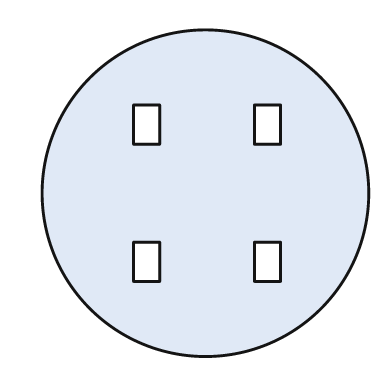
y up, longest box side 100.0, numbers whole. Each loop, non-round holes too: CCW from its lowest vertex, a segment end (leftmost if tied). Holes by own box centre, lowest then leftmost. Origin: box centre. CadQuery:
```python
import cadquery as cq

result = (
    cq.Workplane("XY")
    .moveTo(0.0, 0.0)
    .circle(50.0)
    .moveTo(-22.0, -27.0)
    .lineTo(-14.0, -27.0)
    .lineTo(-14.0, -15.0)
    .lineTo(-22.0, -15.0)
    .close()
    .moveTo(15.0, -27.0)
    .lineTo(23.0, -27.0)
    .lineTo(23.0, -15.0)
    .lineTo(15.0, -15.0)
    .close()
    .moveTo(-22.0, 15.0)
    .lineTo(-14.0, 15.0)
    .lineTo(-14.0, 27.0)
    .lineTo(-22.0, 27.0)
    .close()
    .moveTo(15.0, 15.0)
    .lineTo(23.0, 15.0)
    .lineTo(23.0, 27.0)
    .lineTo(15.0, 27.0)
    .close()
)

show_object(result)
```